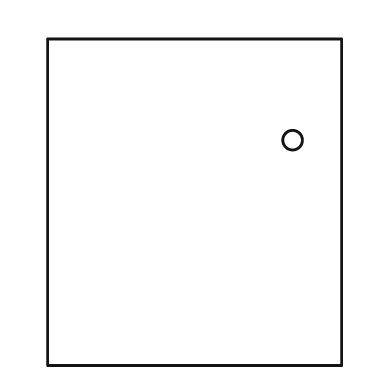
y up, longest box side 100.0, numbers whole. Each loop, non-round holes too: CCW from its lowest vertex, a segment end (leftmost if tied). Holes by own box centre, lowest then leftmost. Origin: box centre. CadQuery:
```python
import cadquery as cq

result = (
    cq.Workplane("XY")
    .moveTo(-45.0, -50.0)
    .lineTo(45.0, -50.0)
    .lineTo(45.0, 50.0)
    .lineTo(-45.0, 50.0)
    .close()
    .moveTo(30.0, 19.0)
    .circle(3.0)
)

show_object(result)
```